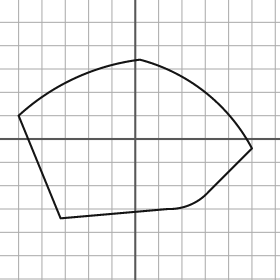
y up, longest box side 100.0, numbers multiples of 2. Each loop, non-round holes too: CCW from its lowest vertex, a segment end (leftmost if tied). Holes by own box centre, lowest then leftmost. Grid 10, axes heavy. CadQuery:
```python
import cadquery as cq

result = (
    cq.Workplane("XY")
    .moveTo(-32.0, -34.0)
    .lineTo(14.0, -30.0)
    .threePointArc((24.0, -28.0), (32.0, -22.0))
    .lineTo(50.0, -4.0)
    .threePointArc((30.0, 20.0), (2.0, 34.0))
    .threePointArc((-26.0, 26.0), (-50.0, 10.0))
    .close()
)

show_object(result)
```